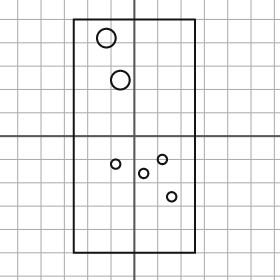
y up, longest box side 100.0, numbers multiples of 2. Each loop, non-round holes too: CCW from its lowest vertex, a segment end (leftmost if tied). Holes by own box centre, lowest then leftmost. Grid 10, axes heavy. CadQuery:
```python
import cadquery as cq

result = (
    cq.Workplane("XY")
    .moveTo(-26.0, -50.0)
    .lineTo(26.0, -50.0)
    .lineTo(26.0, 50.0)
    .lineTo(-26.0, 50.0)
    .close()
    .moveTo(16.0, -26.0)
    .circle(2.0)
    .moveTo(4.0, -16.0)
    .circle(2.0)
    .moveTo(-8.0, -12.0)
    .circle(2.0)
    .moveTo(12.0, -10.0)
    .circle(2.0)
    .moveTo(-6.0, 24.0)
    .circle(4.0)
    .moveTo(-12.0, 42.0)
    .circle(4.0)
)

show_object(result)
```